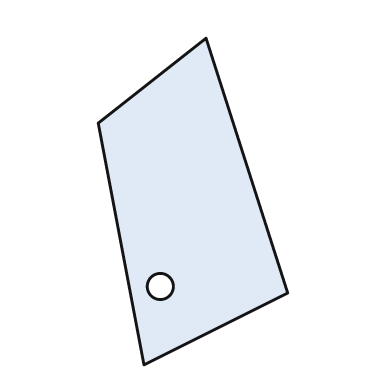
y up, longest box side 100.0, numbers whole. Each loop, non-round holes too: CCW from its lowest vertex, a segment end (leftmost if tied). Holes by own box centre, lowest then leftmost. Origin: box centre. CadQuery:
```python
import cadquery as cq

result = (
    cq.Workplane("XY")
    .moveTo(-15.0, -50.0)
    .lineTo(29.0, -28.0)
    .lineTo(4.0, 50.0)
    .lineTo(-29.0, 24.0)
    .close()
    .moveTo(-10.0, -26.0)
    .circle(4.0)
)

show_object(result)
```